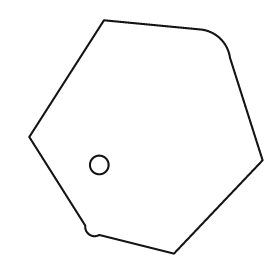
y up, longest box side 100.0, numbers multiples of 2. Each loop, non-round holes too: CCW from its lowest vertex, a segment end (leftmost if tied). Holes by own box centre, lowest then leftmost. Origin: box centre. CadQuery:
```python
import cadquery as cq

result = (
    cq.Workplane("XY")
    .moveTo(12.0, -50.0)
    .lineTo(50.0, -10.0)
    .lineTo(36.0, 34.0)
    .threePointArc((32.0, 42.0), (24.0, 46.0))
    .lineTo(-18.0, 50.0)
    .lineTo(-50.0, 0.0)
    .lineTo(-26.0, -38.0)
    .threePointArc((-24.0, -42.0), (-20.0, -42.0))
    .close()
    .moveTo(-20.0, -12.0)
    .circle(4.0)
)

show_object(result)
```